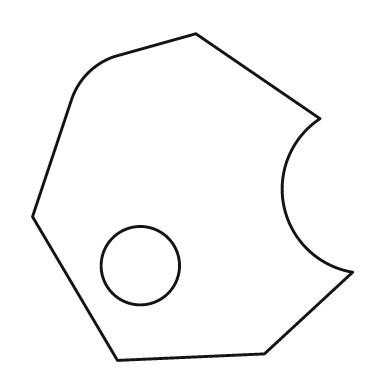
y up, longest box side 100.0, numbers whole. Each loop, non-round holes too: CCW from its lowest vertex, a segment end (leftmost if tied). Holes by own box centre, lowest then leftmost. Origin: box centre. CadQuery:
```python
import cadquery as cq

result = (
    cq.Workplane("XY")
    .moveTo(-23.0, -50.0)
    .lineTo(22.0, -48.0)
    .lineTo(49.0, -23.0)
    .threePointArc((28.0, -3.0), (39.0, 24.0))
    .lineTo(1.0, 50.0)
    .lineTo(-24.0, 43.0)
    .threePointArc((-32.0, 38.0), (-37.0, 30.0))
    .lineTo(-49.0, -6.0)
    .close()
    .moveTo(-16.0, -21.0)
    .circle(12.0)
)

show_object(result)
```